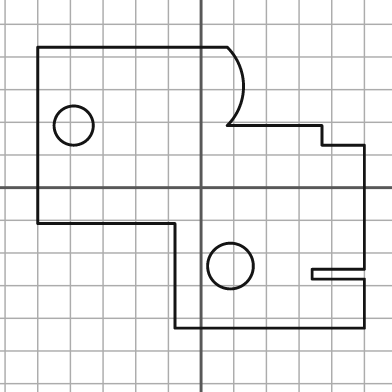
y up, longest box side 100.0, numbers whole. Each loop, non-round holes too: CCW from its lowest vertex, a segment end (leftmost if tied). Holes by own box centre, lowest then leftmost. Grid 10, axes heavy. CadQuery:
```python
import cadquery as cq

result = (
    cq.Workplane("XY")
    .moveTo(-8.0, -43.0)
    .lineTo(50.0, -43.0)
    .lineTo(50.0, -28.0)
    .lineTo(34.0, -28.0)
    .lineTo(34.0, -25.0)
    .lineTo(50.0, -25.0)
    .lineTo(50.0, 13.0)
    .lineTo(37.0, 13.0)
    .lineTo(37.0, 19.0)
    .lineTo(8.0, 19.0)
    .threePointArc((13.0, 31.0), (8.0, 43.0))
    .lineTo(-50.0, 43.0)
    .lineTo(-50.0, -11.0)
    .lineTo(-8.0, -11.0)
    .close()
    .moveTo(9.0, -24.0)
    .circle(7.0)
    .moveTo(-39.0, 19.0)
    .circle(6.0)
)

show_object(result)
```